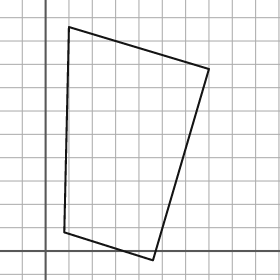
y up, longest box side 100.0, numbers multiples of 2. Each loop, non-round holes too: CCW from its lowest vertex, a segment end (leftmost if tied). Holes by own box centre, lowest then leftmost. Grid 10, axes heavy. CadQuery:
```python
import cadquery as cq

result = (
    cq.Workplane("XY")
    .moveTo(46.0, -4.0)
    .lineTo(70.0, 78.0)
    .lineTo(10.0, 96.0)
    .lineTo(8.0, 8.0)
    .close()
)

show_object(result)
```